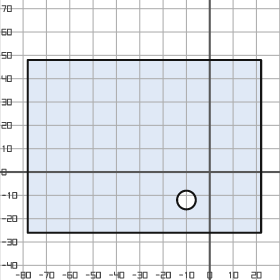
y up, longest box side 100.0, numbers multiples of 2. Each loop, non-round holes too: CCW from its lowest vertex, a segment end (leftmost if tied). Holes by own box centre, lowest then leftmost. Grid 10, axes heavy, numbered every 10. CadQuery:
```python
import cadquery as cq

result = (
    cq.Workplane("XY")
    .moveTo(-78.0, -26.0)
    .lineTo(22.0, -26.0)
    .lineTo(22.0, 48.0)
    .lineTo(-78.0, 48.0)
    .close()
    .moveTo(-10.0, -12.0)
    .circle(4.0)
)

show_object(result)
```